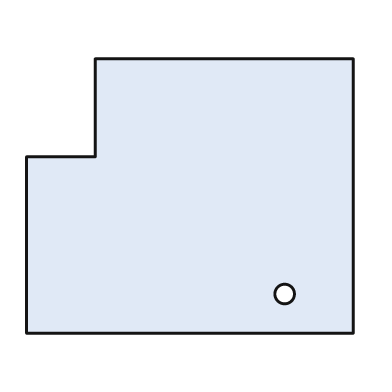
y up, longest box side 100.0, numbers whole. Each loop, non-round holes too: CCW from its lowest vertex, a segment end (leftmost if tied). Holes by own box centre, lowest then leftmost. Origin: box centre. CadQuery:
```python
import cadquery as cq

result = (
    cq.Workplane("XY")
    .moveTo(-50.0, -42.0)
    .lineTo(50.0, -42.0)
    .lineTo(50.0, 42.0)
    .lineTo(-29.0, 42.0)
    .lineTo(-29.0, 12.0)
    .lineTo(-50.0, 12.0)
    .close()
    .moveTo(29.0, -30.0)
    .circle(3.0)
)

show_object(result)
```